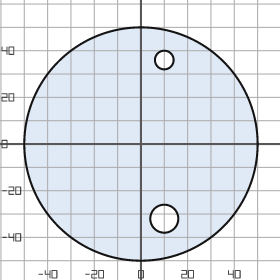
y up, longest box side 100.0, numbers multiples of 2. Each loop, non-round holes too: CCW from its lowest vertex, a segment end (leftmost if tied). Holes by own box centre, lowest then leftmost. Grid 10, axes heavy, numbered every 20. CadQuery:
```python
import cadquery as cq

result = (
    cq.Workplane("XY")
    .moveTo(0.0, 0.0)
    .circle(50.0)
    .moveTo(10.0, -32.0)
    .circle(6.0)
    .moveTo(10.0, 36.0)
    .circle(4.0)
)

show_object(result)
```